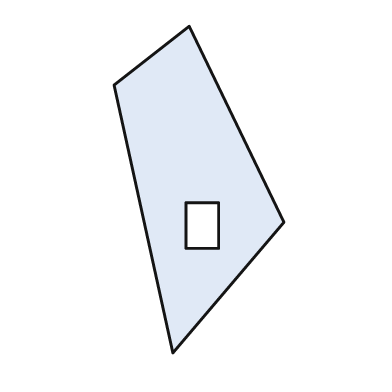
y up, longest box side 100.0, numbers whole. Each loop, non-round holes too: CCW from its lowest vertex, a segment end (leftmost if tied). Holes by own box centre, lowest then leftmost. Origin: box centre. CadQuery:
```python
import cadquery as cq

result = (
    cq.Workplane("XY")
    .moveTo(-8.0, -50.0)
    .lineTo(26.0, -10.0)
    .lineTo(-3.0, 50.0)
    .lineTo(-26.0, 32.0)
    .close()
    .moveTo(-4.0, -18.0)
    .lineTo(6.0, -18.0)
    .lineTo(6.0, -4.0)
    .lineTo(-4.0, -4.0)
    .close()
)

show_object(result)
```